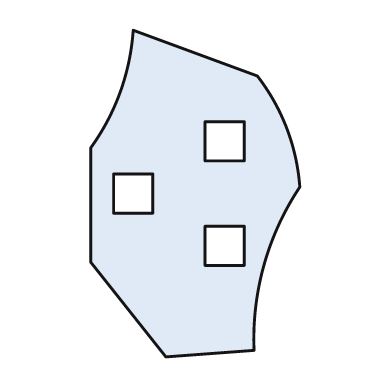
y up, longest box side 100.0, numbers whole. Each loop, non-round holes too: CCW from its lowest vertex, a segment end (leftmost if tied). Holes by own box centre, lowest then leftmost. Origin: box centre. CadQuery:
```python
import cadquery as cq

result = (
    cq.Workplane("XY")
    .moveTo(-9.0, -50.0)
    .lineTo(18.0, -48.0)
    .threePointArc((21.0, -22.0), (32.0, 2.0))
    .threePointArc((28.0, 20.0), (19.0, 36.0))
    .lineTo(-19.0, 50.0)
    .threePointArc((-23.0, 31.0), (-32.0, 14.0))
    .lineTo(-32.0, -21.0)
    .close()
    .moveTo(3.0, -22.0)
    .lineTo(15.0, -22.0)
    .lineTo(15.0, -10.0)
    .lineTo(3.0, -10.0)
    .close()
    .moveTo(-25.0, -6.0)
    .lineTo(-13.0, -6.0)
    .lineTo(-13.0, 6.0)
    .lineTo(-25.0, 6.0)
    .close()
    .moveTo(3.0, 10.0)
    .lineTo(15.0, 10.0)
    .lineTo(15.0, 22.0)
    .lineTo(3.0, 22.0)
    .close()
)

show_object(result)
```